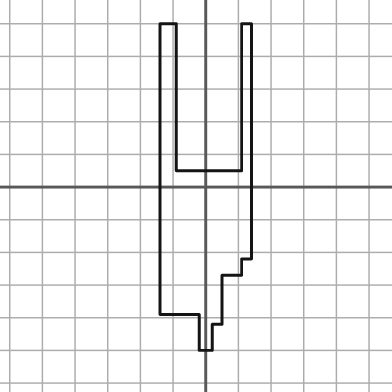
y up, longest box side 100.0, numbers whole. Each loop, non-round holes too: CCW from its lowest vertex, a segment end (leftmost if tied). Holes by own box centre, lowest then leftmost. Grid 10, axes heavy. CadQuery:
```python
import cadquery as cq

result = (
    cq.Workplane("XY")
    .moveTo(-2.0, -50.0)
    .lineTo(2.0, -50.0)
    .lineTo(2.0, -42.0)
    .lineTo(5.0, -42.0)
    .lineTo(5.0, -27.0)
    .lineTo(11.0, -27.0)
    .lineTo(11.0, -22.0)
    .lineTo(14.0, -22.0)
    .lineTo(14.0, 50.0)
    .lineTo(11.0, 50.0)
    .lineTo(11.0, 5.0)
    .lineTo(-9.0, 5.0)
    .lineTo(-9.0, 50.0)
    .lineTo(-14.0, 50.0)
    .lineTo(-14.0, -39.0)
    .lineTo(-2.0, -39.0)
    .close()
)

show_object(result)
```